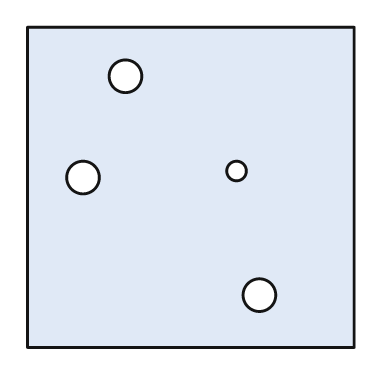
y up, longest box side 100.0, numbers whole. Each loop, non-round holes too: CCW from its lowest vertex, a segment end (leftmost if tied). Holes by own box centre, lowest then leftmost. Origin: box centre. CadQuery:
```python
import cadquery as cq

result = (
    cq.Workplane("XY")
    .moveTo(-50.0, -49.0)
    .lineTo(50.0, -49.0)
    .lineTo(50.0, 49.0)
    .lineTo(-50.0, 49.0)
    .close()
    .moveTo(21.0, -33.0)
    .circle(5.0)
    .moveTo(-33.0, 3.0)
    .circle(5.0)
    .moveTo(14.0, 5.0)
    .circle(3.0)
    .moveTo(-20.0, 34.0)
    .circle(5.0)
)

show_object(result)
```